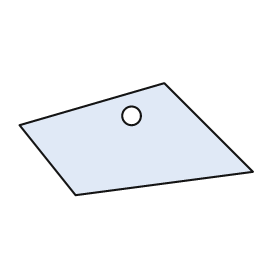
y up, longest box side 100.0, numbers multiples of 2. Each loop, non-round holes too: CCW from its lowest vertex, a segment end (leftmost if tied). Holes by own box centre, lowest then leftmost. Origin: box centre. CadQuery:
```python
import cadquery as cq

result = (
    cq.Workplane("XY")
    .moveTo(-26.0, -24.0)
    .lineTo(50.0, -14.0)
    .lineTo(12.0, 24.0)
    .lineTo(-50.0, 6.0)
    .close()
    .moveTo(-2.0, 10.0)
    .circle(4.0)
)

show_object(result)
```